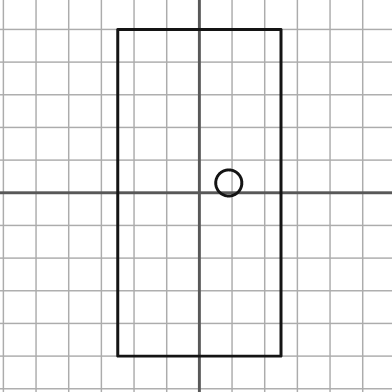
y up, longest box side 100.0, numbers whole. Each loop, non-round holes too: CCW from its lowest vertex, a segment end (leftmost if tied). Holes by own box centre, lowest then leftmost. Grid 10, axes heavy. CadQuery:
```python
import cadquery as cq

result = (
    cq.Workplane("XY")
    .moveTo(-25.0, -50.0)
    .lineTo(25.0, -50.0)
    .lineTo(25.0, 50.0)
    .lineTo(-25.0, 50.0)
    .close()
    .moveTo(9.0, 3.0)
    .circle(4.0)
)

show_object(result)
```